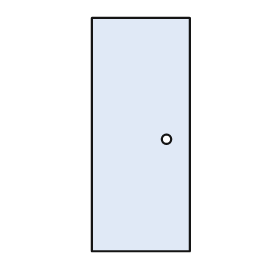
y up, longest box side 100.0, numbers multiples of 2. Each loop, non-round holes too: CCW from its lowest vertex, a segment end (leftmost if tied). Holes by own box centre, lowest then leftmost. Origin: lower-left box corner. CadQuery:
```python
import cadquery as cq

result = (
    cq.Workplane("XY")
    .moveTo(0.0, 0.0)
    .lineTo(42.0, 0.0)
    .lineTo(42.0, 100.0)
    .lineTo(0.0, 100.0)
    .close()
    .moveTo(32.0, 48.0)
    .circle(2.0)
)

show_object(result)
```